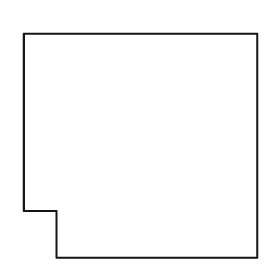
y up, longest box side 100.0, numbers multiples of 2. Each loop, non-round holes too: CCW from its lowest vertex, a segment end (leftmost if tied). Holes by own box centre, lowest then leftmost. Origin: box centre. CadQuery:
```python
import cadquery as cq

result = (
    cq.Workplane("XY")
    .moveTo(-36.0, -48.0)
    .lineTo(50.0, -48.0)
    .lineTo(50.0, 48.0)
    .lineTo(-50.0, 48.0)
    .lineTo(-50.0, -28.0)
    .lineTo(-36.0, -28.0)
    .close()
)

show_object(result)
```